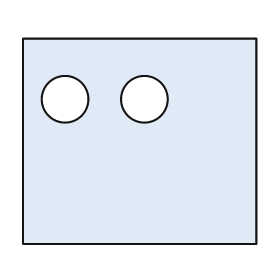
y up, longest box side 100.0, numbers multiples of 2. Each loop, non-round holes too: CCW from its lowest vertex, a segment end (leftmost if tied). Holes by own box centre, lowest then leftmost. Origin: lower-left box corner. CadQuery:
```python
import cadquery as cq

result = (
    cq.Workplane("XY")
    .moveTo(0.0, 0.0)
    .lineTo(100.0, 0.0)
    .lineTo(100.0, 88.0)
    .lineTo(0.0, 88.0)
    .close()
    .moveTo(18.0, 62.0)
    .circle(10.0)
    .moveTo(52.0, 62.0)
    .circle(10.0)
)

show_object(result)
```